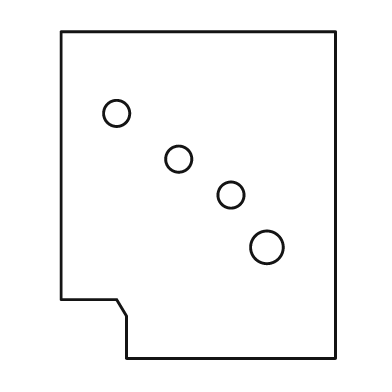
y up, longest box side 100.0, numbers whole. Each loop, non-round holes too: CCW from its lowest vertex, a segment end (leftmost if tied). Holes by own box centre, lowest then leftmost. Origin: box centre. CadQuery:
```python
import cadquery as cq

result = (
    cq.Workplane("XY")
    .moveTo(-22.0, -50.0)
    .lineTo(42.0, -50.0)
    .lineTo(42.0, 50.0)
    .lineTo(-42.0, 50.0)
    .lineTo(-42.0, -32.0)
    .lineTo(-25.0, -32.0)
    .lineTo(-22.0, -37.0)
    .close()
    .moveTo(21.0, -16.0)
    .circle(5.0)
    .moveTo(10.0, 0.0)
    .circle(4.0)
    .moveTo(-6.0, 11.0)
    .circle(4.0)
    .moveTo(-25.0, 25.0)
    .circle(4.0)
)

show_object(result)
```